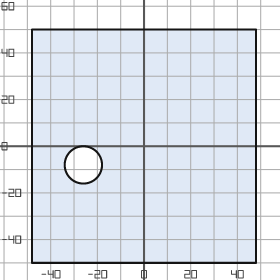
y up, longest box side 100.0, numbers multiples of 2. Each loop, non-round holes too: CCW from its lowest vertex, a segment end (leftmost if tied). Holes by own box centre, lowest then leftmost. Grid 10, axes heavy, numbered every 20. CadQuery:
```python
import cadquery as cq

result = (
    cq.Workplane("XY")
    .moveTo(-48.0, -50.0)
    .lineTo(48.0, -50.0)
    .lineTo(48.0, 50.0)
    .lineTo(-48.0, 50.0)
    .close()
    .moveTo(-26.0, -8.0)
    .circle(8.0)
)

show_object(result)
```